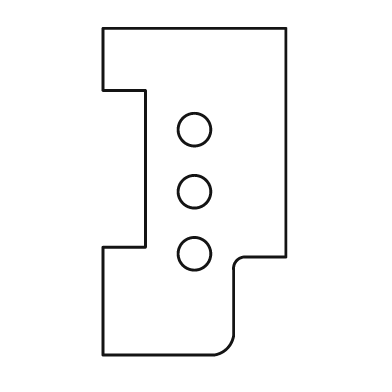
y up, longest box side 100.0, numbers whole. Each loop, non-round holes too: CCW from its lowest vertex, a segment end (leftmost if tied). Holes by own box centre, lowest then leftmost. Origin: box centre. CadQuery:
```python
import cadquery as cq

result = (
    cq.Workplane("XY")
    .moveTo(-28.0, -50.0)
    .lineTo(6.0, -50.0)
    .threePointArc((10.0, -48.0), (12.0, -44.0))
    .lineTo(12.0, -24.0)
    .threePointArc((13.0, -21.0), (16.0, -20.0))
    .lineTo(28.0, -20.0)
    .lineTo(28.0, 50.0)
    .lineTo(-28.0, 50.0)
    .lineTo(-28.0, 31.0)
    .lineTo(-15.0, 31.0)
    .lineTo(-15.0, -17.0)
    .lineTo(-28.0, -17.0)
    .close()
    .moveTo(0.0, -19.0)
    .circle(5.0)
    .moveTo(0.0, 0.0)
    .circle(5.0)
    .moveTo(0.0, 19.0)
    .circle(5.0)
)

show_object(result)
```